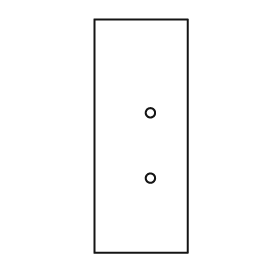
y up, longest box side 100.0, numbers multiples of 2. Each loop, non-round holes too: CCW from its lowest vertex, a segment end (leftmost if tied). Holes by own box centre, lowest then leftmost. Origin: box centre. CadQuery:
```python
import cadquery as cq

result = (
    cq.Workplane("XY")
    .moveTo(-20.0, -50.0)
    .lineTo(20.0, -50.0)
    .lineTo(20.0, 50.0)
    .lineTo(-20.0, 50.0)
    .close()
    .moveTo(4.0, -18.0)
    .circle(2.0)
    .moveTo(4.0, 10.0)
    .circle(2.0)
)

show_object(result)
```